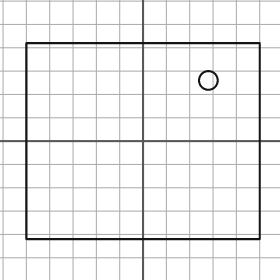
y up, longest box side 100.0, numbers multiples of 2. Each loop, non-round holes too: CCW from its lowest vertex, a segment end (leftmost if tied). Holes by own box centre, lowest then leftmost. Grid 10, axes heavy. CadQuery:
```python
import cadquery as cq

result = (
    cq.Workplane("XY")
    .moveTo(-50.0, -42.0)
    .lineTo(50.0, -42.0)
    .lineTo(50.0, 42.0)
    .lineTo(-50.0, 42.0)
    .close()
    .moveTo(28.0, 26.0)
    .circle(4.0)
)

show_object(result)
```